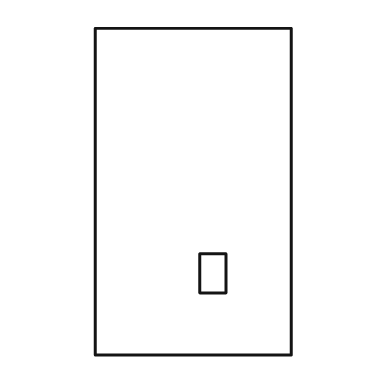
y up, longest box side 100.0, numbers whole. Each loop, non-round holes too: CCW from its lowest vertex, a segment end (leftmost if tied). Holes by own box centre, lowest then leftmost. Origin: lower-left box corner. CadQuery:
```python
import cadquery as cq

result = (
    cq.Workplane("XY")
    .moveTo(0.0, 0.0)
    .lineTo(60.0, 0.0)
    .lineTo(60.0, 100.0)
    .lineTo(0.0, 100.0)
    .close()
    .moveTo(32.0, 19.0)
    .lineTo(40.0, 19.0)
    .lineTo(40.0, 31.0)
    .lineTo(32.0, 31.0)
    .close()
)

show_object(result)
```